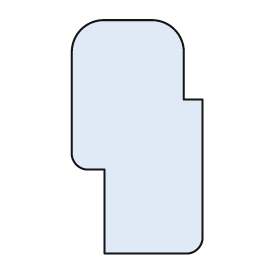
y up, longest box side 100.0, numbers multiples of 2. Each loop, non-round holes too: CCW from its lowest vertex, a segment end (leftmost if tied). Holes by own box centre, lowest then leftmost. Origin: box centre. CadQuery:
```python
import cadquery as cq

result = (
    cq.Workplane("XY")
    .moveTo(-14.0, -50.0)
    .lineTo(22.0, -50.0)
    .threePointArc((26.0, -48.0), (28.0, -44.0))
    .lineTo(28.0, 16.0)
    .lineTo(20.0, 16.0)
    .lineTo(20.0, 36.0)
    .threePointArc((16.0, 46.0), (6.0, 50.0))
    .lineTo(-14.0, 50.0)
    .threePointArc((-24.0, 46.0), (-28.0, 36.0))
    .lineTo(-28.0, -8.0)
    .threePointArc((-26.0, -12.0), (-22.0, -14.0))
    .lineTo(-14.0, -14.0)
    .close()
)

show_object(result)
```